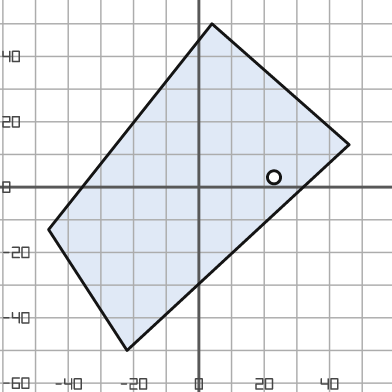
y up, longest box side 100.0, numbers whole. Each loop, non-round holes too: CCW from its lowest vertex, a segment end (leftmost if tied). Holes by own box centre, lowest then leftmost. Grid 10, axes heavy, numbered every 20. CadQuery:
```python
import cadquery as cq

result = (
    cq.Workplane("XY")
    .moveTo(-22.0, -50.0)
    .lineTo(46.0, 13.0)
    .lineTo(4.0, 50.0)
    .lineTo(-46.0, -13.0)
    .close()
    .moveTo(23.0, 3.0)
    .circle(2.0)
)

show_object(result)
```